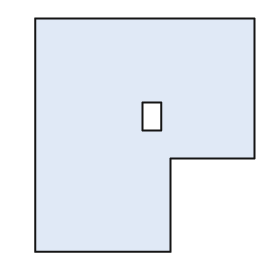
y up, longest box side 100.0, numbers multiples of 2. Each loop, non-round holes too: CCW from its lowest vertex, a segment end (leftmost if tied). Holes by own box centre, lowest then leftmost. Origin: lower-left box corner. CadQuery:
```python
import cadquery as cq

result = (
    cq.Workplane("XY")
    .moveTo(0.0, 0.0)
    .lineTo(58.0, 0.0)
    .lineTo(58.0, 40.0)
    .lineTo(94.0, 40.0)
    .lineTo(94.0, 100.0)
    .lineTo(0.0, 100.0)
    .close()
    .moveTo(46.0, 52.0)
    .lineTo(54.0, 52.0)
    .lineTo(54.0, 64.0)
    .lineTo(46.0, 64.0)
    .close()
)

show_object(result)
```